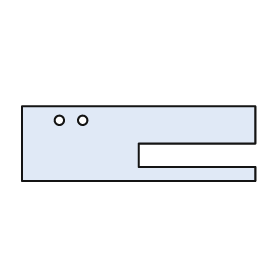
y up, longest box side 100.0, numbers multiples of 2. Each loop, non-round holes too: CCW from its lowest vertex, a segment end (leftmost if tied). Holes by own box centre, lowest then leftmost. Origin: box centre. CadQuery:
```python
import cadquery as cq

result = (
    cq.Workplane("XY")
    .moveTo(-50.0, -16.0)
    .lineTo(50.0, -16.0)
    .lineTo(50.0, -10.0)
    .lineTo(0.0, -10.0)
    .lineTo(0.0, 0.0)
    .lineTo(50.0, 0.0)
    .lineTo(50.0, 16.0)
    .lineTo(-50.0, 16.0)
    .close()
    .moveTo(-34.0, 10.0)
    .circle(2.0)
    .moveTo(-24.0, 10.0)
    .circle(2.0)
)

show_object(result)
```